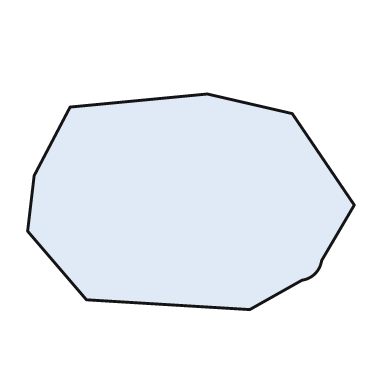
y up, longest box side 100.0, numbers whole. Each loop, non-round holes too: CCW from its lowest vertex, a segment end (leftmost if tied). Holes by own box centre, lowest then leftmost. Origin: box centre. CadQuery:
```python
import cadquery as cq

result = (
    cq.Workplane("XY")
    .moveTo(18.0, -33.0)
    .lineTo(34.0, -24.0)
    .threePointArc((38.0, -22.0), (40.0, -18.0))
    .lineTo(50.0, -1.0)
    .lineTo(31.0, 27.0)
    .lineTo(5.0, 33.0)
    .lineTo(-37.0, 29.0)
    .lineTo(-48.0, 8.0)
    .lineTo(-50.0, -9.0)
    .lineTo(-32.0, -30.0)
    .close()
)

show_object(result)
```